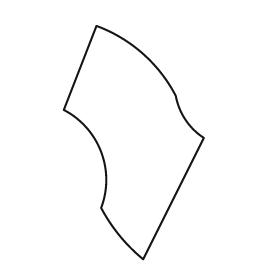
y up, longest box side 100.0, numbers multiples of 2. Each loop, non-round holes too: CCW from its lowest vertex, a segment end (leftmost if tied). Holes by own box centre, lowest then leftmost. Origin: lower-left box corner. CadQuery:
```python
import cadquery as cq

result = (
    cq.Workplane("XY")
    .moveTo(34.0, 0.0)
    .lineTo(60.0, 52.0)
    .threePointArc((52.0, 60.0), (48.0, 70.0))
    .threePointArc((34.0, 88.0), (14.0, 100.0))
    .lineTo(0.0, 64.0)
    .threePointArc((16.0, 46.0), (16.0, 22.0))
    .threePointArc((24.0, 10.0), (34.0, 0.0))
    .close()
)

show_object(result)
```